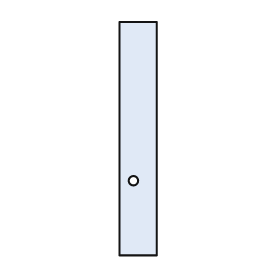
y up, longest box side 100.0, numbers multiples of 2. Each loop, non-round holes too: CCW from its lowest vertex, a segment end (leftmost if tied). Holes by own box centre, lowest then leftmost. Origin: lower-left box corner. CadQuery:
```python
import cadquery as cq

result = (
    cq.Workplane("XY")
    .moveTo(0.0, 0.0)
    .lineTo(16.0, 0.0)
    .lineTo(16.0, 100.0)
    .lineTo(0.0, 100.0)
    .close()
    .moveTo(6.0, 32.0)
    .circle(2.0)
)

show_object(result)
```